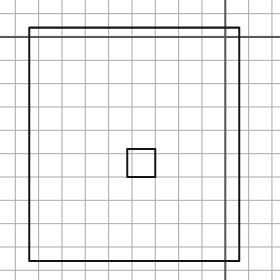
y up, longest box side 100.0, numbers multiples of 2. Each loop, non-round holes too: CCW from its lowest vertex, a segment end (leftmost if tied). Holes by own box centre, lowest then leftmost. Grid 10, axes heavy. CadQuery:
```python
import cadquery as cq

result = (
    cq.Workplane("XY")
    .moveTo(-84.0, -96.0)
    .lineTo(6.0, -96.0)
    .lineTo(6.0, 4.0)
    .lineTo(-84.0, 4.0)
    .close()
    .moveTo(-42.0, -60.0)
    .lineTo(-30.0, -60.0)
    .lineTo(-30.0, -48.0)
    .lineTo(-42.0, -48.0)
    .close()
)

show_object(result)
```